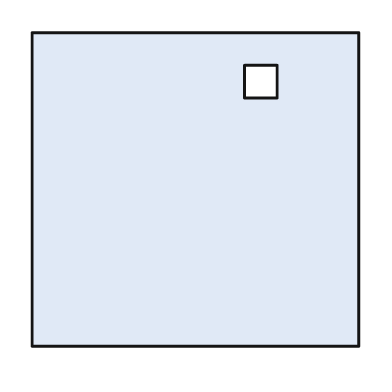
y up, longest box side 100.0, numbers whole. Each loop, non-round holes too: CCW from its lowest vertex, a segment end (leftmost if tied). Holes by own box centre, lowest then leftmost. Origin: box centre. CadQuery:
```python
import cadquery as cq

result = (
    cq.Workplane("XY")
    .moveTo(-50.0, -48.0)
    .lineTo(50.0, -48.0)
    .lineTo(50.0, 48.0)
    .lineTo(-50.0, 48.0)
    .close()
    .moveTo(15.0, 28.0)
    .lineTo(25.0, 28.0)
    .lineTo(25.0, 38.0)
    .lineTo(15.0, 38.0)
    .close()
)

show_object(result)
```